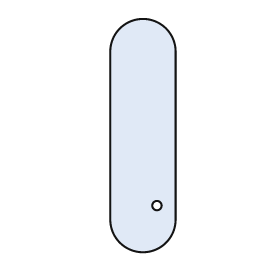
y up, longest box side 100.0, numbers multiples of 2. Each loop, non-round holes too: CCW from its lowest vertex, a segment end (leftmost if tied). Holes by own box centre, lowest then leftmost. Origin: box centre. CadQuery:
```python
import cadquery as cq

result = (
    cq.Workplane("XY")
    .moveTo(-14.0, -36.0)
    .threePointArc((0.0, -50.0), (14.0, -36.0))
    .lineTo(14.0, 36.0)
    .threePointArc((0.0, 50.0), (-14.0, 36.0))
    .close()
    .moveTo(6.0, -30.0)
    .circle(2.0)
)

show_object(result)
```